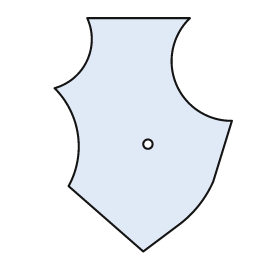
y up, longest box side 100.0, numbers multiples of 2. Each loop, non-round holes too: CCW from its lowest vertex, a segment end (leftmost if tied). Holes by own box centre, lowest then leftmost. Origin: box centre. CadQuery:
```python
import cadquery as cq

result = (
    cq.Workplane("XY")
    .moveTo(0.0, -50.0)
    .lineTo(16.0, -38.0)
    .threePointArc((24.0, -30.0), (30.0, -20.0))
    .lineTo(38.0, 6.0)
    .threePointArc((14.0, 22.0), (20.0, 50.0))
    .lineTo(-24.0, 50.0)
    .threePointArc((-24.0, 32.0), (-38.0, 20.0))
    .threePointArc((-28.0, 0.0), (-32.0, -22.0))
    .close()
    .moveTo(2.0, -4.0)
    .circle(2.0)
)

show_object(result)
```